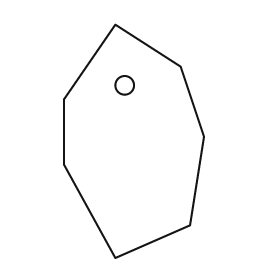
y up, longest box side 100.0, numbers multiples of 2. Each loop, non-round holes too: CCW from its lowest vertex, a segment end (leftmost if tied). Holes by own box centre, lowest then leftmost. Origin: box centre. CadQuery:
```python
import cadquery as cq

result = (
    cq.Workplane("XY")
    .moveTo(-8.0, -50.0)
    .lineTo(24.0, -36.0)
    .lineTo(30.0, 2.0)
    .lineTo(20.0, 32.0)
    .lineTo(-8.0, 50.0)
    .lineTo(-30.0, 18.0)
    .lineTo(-30.0, -10.0)
    .close()
    .moveTo(-4.0, 24.0)
    .circle(4.0)
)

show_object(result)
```